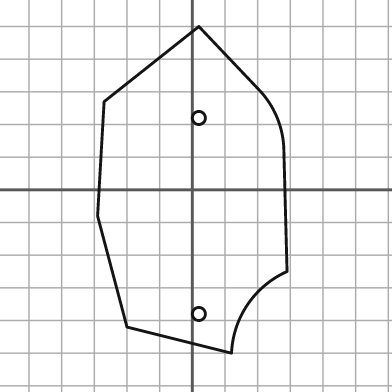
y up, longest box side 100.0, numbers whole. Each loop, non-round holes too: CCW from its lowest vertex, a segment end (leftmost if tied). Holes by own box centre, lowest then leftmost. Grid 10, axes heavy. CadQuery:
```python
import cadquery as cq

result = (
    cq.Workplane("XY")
    .moveTo(12.0, -50.0)
    .threePointArc((17.0, -35.0), (29.0, -25.0))
    .lineTo(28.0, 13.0)
    .threePointArc((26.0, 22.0), (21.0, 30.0))
    .lineTo(2.0, 50.0)
    .lineTo(-27.0, 27.0)
    .lineTo(-29.0, -8.0)
    .lineTo(-20.0, -42.0)
    .close()
    .moveTo(2.0, -38.0)
    .circle(2.0)
    .moveTo(2.0, 22.0)
    .circle(2.0)
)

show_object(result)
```